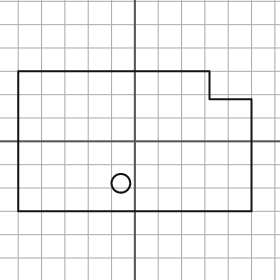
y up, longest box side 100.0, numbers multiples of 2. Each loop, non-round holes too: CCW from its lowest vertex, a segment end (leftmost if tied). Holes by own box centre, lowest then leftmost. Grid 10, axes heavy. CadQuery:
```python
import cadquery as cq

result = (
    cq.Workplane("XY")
    .moveTo(-50.0, -30.0)
    .lineTo(50.0, -30.0)
    .lineTo(50.0, 18.0)
    .lineTo(32.0, 18.0)
    .lineTo(32.0, 30.0)
    .lineTo(-50.0, 30.0)
    .close()
    .moveTo(-6.0, -18.0)
    .circle(4.0)
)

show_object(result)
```